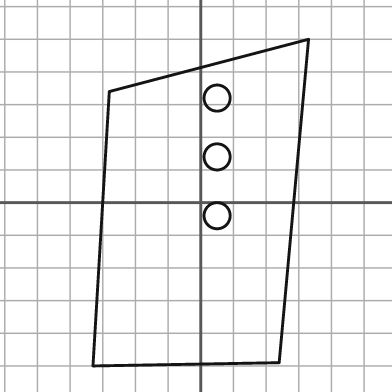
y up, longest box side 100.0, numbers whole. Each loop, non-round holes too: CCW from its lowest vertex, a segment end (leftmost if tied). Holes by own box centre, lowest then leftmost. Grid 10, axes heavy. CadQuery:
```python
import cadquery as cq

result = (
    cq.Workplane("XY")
    .moveTo(-33.0, -50.0)
    .lineTo(24.0, -49.0)
    .lineTo(33.0, 50.0)
    .lineTo(-28.0, 34.0)
    .close()
    .moveTo(5.0, -4.0)
    .circle(4.0)
    .moveTo(5.0, 14.0)
    .circle(4.0)
    .moveTo(5.0, 32.0)
    .circle(4.0)
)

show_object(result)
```